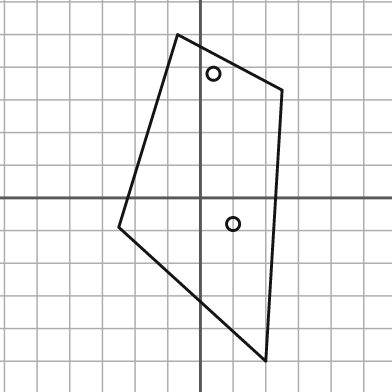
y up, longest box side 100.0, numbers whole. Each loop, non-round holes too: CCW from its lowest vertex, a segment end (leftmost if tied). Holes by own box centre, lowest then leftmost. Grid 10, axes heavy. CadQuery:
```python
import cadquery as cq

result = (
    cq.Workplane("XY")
    .moveTo(20.0, -50.0)
    .lineTo(25.0, 33.0)
    .lineTo(-7.0, 50.0)
    .lineTo(-25.0, -9.0)
    .close()
    .moveTo(10.0, -8.0)
    .circle(2.0)
    .moveTo(4.0, 38.0)
    .circle(2.0)
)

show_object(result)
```